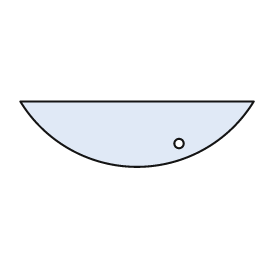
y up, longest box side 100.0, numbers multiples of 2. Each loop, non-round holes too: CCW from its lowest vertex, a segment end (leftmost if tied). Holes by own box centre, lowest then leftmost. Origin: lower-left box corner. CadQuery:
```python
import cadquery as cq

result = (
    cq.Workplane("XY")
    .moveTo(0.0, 28.0)
    .threePointArc((50.0, 0.0), (100.0, 28.0))
    .close()
    .moveTo(68.0, 10.0)
    .circle(2.0)
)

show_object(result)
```